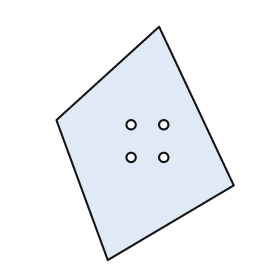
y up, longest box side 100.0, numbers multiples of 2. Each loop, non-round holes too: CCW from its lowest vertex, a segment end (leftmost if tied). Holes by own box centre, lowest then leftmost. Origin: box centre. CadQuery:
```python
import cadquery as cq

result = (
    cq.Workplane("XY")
    .moveTo(-16.0, -50.0)
    .lineTo(38.0, -18.0)
    .lineTo(6.0, 50.0)
    .lineTo(-38.0, 10.0)
    .close()
    .moveTo(-6.0, -6.0)
    .circle(2.0)
    .moveTo(8.0, -6.0)
    .circle(2.0)
    .moveTo(-6.0, 8.0)
    .circle(2.0)
    .moveTo(8.0, 8.0)
    .circle(2.0)
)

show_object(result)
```